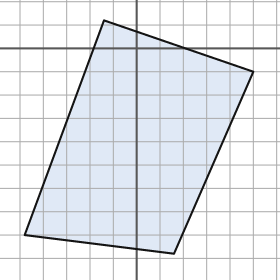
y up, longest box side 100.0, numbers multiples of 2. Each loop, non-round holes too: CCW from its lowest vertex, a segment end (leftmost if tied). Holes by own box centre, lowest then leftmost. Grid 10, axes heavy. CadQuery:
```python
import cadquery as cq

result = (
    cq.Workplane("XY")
    .moveTo(16.0, -88.0)
    .lineTo(50.0, -10.0)
    .lineTo(-14.0, 12.0)
    .lineTo(-48.0, -80.0)
    .close()
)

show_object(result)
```